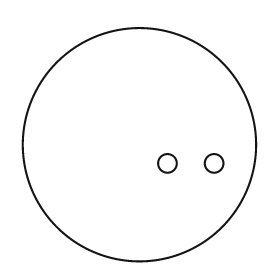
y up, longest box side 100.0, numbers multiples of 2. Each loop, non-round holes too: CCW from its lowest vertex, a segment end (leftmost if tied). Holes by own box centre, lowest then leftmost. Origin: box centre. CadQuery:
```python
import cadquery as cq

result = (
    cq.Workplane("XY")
    .moveTo(0.0, 0.0)
    .circle(50.0)
    .moveTo(12.0, -8.0)
    .circle(4.0)
    .moveTo(32.0, -8.0)
    .circle(4.0)
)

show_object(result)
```